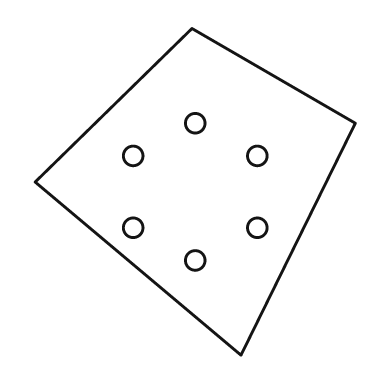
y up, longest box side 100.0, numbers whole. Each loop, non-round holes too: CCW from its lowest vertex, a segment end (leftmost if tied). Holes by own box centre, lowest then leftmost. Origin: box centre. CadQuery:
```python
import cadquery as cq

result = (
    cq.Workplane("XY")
    .moveTo(14.0, -50.0)
    .lineTo(49.0, 21.0)
    .lineTo(-1.0, 50.0)
    .lineTo(-49.0, 3.0)
    .close()
    .moveTo(0.0, -21.0)
    .circle(3.0)
    .moveTo(-19.0, -11.0)
    .circle(3.0)
    .moveTo(19.0, -11.0)
    .circle(3.0)
    .moveTo(-19.0, 11.0)
    .circle(3.0)
    .moveTo(19.0, 11.0)
    .circle(3.0)
    .moveTo(0.0, 21.0)
    .circle(3.0)
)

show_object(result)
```